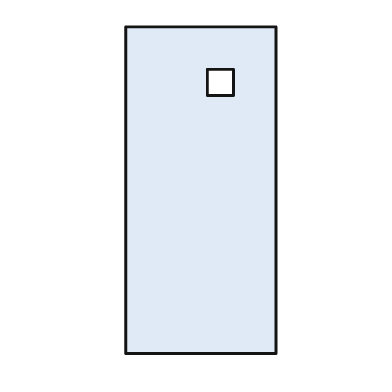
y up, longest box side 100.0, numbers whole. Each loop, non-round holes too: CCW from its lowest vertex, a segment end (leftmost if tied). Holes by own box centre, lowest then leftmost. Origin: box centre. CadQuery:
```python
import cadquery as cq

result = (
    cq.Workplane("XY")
    .moveTo(-23.0, -50.0)
    .lineTo(23.0, -50.0)
    .lineTo(23.0, 50.0)
    .lineTo(-23.0, 50.0)
    .close()
    .moveTo(2.0, 29.0)
    .lineTo(10.0, 29.0)
    .lineTo(10.0, 37.0)
    .lineTo(2.0, 37.0)
    .close()
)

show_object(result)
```